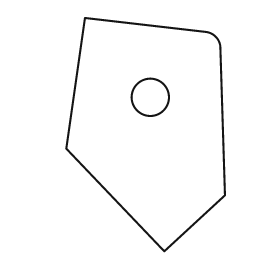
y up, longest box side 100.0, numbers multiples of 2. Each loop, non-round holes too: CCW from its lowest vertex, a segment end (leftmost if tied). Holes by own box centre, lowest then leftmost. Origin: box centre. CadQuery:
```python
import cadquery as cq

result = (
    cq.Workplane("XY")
    .moveTo(8.0, -50.0)
    .lineTo(34.0, -26.0)
    .lineTo(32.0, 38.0)
    .threePointArc((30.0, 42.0), (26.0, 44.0))
    .lineTo(-26.0, 50.0)
    .lineTo(-34.0, -6.0)
    .close()
    .moveTo(2.0, 16.0)
    .circle(8.0)
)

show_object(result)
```